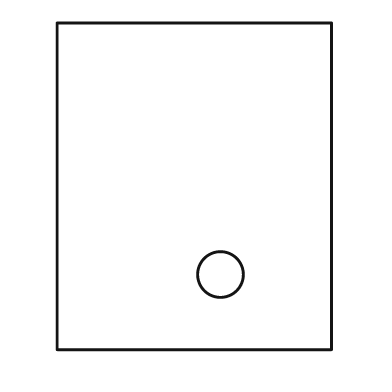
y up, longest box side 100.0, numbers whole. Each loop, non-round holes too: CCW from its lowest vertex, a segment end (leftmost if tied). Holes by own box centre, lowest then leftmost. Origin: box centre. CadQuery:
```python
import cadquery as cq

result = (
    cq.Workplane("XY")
    .moveTo(-42.0, -50.0)
    .lineTo(42.0, -50.0)
    .lineTo(42.0, 50.0)
    .lineTo(-42.0, 50.0)
    .close()
    .moveTo(8.0, -27.0)
    .circle(7.0)
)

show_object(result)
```